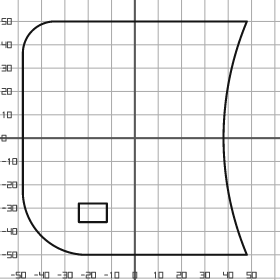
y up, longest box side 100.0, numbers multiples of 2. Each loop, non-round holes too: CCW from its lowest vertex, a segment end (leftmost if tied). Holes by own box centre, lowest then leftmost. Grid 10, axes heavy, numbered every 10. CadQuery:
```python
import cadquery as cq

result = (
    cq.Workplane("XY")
    .moveTo(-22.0, -50.0)
    .lineTo(48.0, -50.0)
    .threePointArc((38.0, 0.0), (48.0, 50.0))
    .lineTo(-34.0, 50.0)
    .threePointArc((-44.0, 46.0), (-48.0, 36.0))
    .lineTo(-48.0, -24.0)
    .threePointArc((-40.0, -42.0), (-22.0, -50.0))
    .close()
    .moveTo(-24.0, -36.0)
    .lineTo(-12.0, -36.0)
    .lineTo(-12.0, -28.0)
    .lineTo(-24.0, -28.0)
    .close()
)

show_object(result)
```